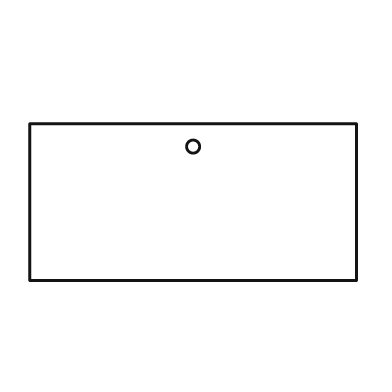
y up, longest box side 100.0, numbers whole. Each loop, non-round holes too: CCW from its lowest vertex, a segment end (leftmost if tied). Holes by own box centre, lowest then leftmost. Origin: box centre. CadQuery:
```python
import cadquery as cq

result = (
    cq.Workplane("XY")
    .moveTo(-50.0, -24.0)
    .lineTo(50.0, -24.0)
    .lineTo(50.0, 24.0)
    .lineTo(-50.0, 24.0)
    .close()
    .moveTo(0.0, 17.0)
    .circle(2.0)
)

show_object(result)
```